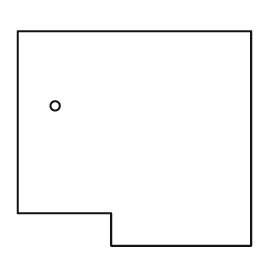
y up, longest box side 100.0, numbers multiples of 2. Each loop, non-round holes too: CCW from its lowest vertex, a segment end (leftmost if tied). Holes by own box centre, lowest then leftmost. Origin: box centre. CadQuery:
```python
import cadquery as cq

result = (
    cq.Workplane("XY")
    .moveTo(-10.0, -46.0)
    .lineTo(50.0, -46.0)
    .lineTo(50.0, 46.0)
    .lineTo(-50.0, 46.0)
    .lineTo(-50.0, -32.0)
    .lineTo(-10.0, -32.0)
    .close()
    .moveTo(-34.0, 14.0)
    .circle(2.0)
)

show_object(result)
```